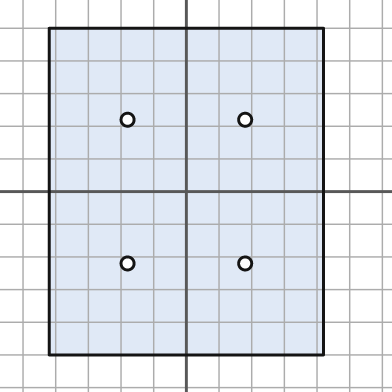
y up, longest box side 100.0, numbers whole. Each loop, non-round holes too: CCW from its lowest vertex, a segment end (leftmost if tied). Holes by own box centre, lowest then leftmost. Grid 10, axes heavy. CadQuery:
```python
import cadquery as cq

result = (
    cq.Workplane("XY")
    .moveTo(-42.0, -50.0)
    .lineTo(42.0, -50.0)
    .lineTo(42.0, 50.0)
    .lineTo(-42.0, 50.0)
    .close()
    .moveTo(-18.0, -22.0)
    .circle(2.0)
    .moveTo(18.0, -22.0)
    .circle(2.0)
    .moveTo(-18.0, 22.0)
    .circle(2.0)
    .moveTo(18.0, 22.0)
    .circle(2.0)
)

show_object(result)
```